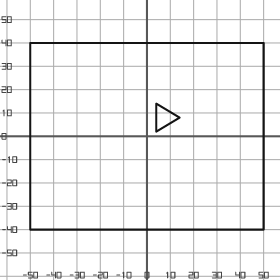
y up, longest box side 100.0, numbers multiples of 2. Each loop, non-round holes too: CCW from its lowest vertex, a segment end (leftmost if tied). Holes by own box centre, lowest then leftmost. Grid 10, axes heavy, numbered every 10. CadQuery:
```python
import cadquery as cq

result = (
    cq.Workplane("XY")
    .moveTo(-50.0, -40.0)
    .lineTo(50.0, -40.0)
    .lineTo(50.0, 40.0)
    .lineTo(-50.0, 40.0)
    .close()
    .moveTo(4.0, 2.0)
    .lineTo(14.0, 8.0)
    .lineTo(4.0, 14.0)
    .close()
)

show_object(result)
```